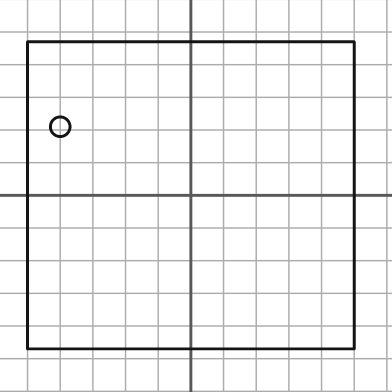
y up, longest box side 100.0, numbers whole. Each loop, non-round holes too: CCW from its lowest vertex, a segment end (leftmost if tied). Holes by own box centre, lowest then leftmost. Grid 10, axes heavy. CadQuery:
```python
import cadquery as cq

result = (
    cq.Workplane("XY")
    .moveTo(-50.0, -47.0)
    .lineTo(50.0, -47.0)
    .lineTo(50.0, 47.0)
    .lineTo(-50.0, 47.0)
    .close()
    .moveTo(-40.0, 21.0)
    .circle(3.0)
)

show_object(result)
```